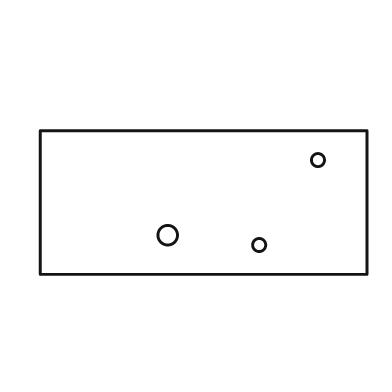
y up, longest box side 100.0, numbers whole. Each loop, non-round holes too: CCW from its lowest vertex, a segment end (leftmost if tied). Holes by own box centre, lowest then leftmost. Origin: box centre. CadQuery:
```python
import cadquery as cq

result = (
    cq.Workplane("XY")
    .moveTo(-50.0, -22.0)
    .lineTo(50.0, -22.0)
    .lineTo(50.0, 22.0)
    .lineTo(-50.0, 22.0)
    .close()
    .moveTo(17.0, -13.0)
    .circle(2.0)
    .moveTo(-11.0, -10.0)
    .circle(3.0)
    .moveTo(35.0, 13.0)
    .circle(2.0)
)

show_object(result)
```